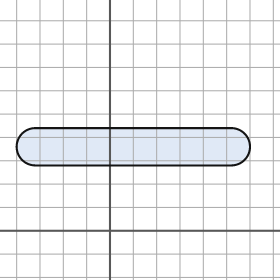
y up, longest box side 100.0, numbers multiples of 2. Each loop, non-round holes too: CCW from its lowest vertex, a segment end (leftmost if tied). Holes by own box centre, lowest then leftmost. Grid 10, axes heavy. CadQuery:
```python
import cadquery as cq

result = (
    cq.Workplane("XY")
    .moveTo(-32.0, 28.0)
    .lineTo(52.0, 28.0)
    .threePointArc((60.0, 36.0), (52.0, 44.0))
    .lineTo(-32.0, 44.0)
    .threePointArc((-40.0, 36.0), (-32.0, 28.0))
    .close()
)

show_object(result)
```